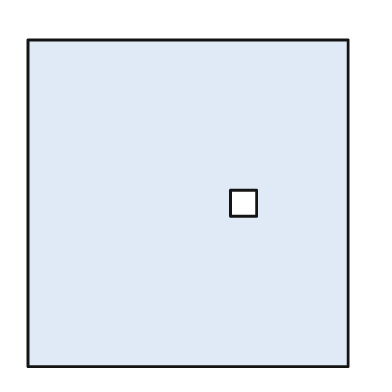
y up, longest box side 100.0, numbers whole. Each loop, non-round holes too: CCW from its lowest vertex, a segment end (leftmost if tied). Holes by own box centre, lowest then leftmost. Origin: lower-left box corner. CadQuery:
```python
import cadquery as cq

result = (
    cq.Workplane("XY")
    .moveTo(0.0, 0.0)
    .lineTo(98.0, 0.0)
    .lineTo(98.0, 100.0)
    .lineTo(0.0, 100.0)
    .close()
    .moveTo(62.0, 46.0)
    .lineTo(70.0, 46.0)
    .lineTo(70.0, 54.0)
    .lineTo(62.0, 54.0)
    .close()
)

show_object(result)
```